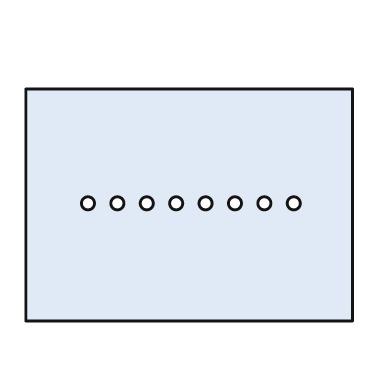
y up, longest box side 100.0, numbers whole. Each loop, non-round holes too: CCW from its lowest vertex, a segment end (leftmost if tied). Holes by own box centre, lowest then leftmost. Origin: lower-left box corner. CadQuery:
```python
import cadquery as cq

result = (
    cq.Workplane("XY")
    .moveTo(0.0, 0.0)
    .lineTo(100.0, 0.0)
    .lineTo(100.0, 71.0)
    .lineTo(0.0, 71.0)
    .close()
    .moveTo(19.0, 36.0)
    .circle(2.0)
    .moveTo(28.0, 36.0)
    .circle(2.0)
    .moveTo(37.0, 36.0)
    .circle(2.0)
    .moveTo(46.0, 36.0)
    .circle(2.0)
    .moveTo(55.0, 36.0)
    .circle(2.0)
    .moveTo(64.0, 36.0)
    .circle(2.0)
    .moveTo(73.0, 36.0)
    .circle(2.0)
    .moveTo(82.0, 36.0)
    .circle(2.0)
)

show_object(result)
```